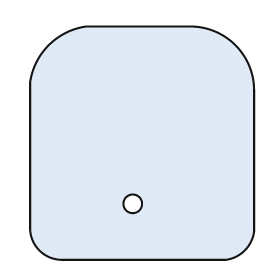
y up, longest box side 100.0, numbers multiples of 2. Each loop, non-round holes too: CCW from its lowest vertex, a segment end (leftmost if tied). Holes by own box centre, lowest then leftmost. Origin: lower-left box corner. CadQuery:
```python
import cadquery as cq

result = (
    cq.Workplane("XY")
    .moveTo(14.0, 0.0)
    .lineTo(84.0, 0.0)
    .threePointArc((92.0, 4.0), (96.0, 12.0))
    .lineTo(96.0, 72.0)
    .threePointArc((88.0, 92.0), (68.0, 100.0))
    .lineTo(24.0, 100.0)
    .threePointArc((8.0, 92.0), (0.0, 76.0))
    .lineTo(0.0, 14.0)
    .threePointArc((4.0, 4.0), (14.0, 0.0))
    .close()
    .moveTo(44.0, 24.0)
    .circle(4.0)
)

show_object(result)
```